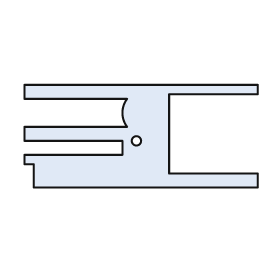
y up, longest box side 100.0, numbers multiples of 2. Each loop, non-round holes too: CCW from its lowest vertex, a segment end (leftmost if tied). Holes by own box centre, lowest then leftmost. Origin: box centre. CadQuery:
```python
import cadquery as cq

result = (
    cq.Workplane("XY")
    .moveTo(-46.0, -22.0)
    .lineTo(50.0, -22.0)
    .lineTo(50.0, -16.0)
    .lineTo(12.0, -16.0)
    .lineTo(12.0, 18.0)
    .lineTo(50.0, 18.0)
    .lineTo(50.0, 22.0)
    .lineTo(-50.0, 22.0)
    .lineTo(-50.0, 16.0)
    .lineTo(-6.0, 16.0)
    .threePointArc((-8.0, 10.0), (-6.0, 4.0))
    .lineTo(-50.0, 4.0)
    .lineTo(-50.0, -2.0)
    .lineTo(-8.0, -2.0)
    .lineTo(-8.0, -8.0)
    .lineTo(-50.0, -8.0)
    .lineTo(-50.0, -12.0)
    .lineTo(-46.0, -12.0)
    .close()
    .moveTo(-2.0, -2.0)
    .circle(2.0)
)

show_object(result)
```